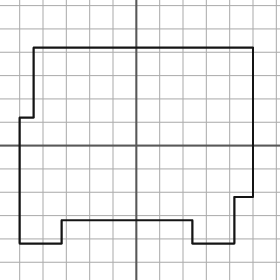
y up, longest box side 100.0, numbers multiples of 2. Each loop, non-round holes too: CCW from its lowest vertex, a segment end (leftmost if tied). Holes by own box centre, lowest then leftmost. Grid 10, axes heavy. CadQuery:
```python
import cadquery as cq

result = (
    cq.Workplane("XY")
    .moveTo(-50.0, -42.0)
    .lineTo(-32.0, -42.0)
    .lineTo(-32.0, -32.0)
    .lineTo(24.0, -32.0)
    .lineTo(24.0, -42.0)
    .lineTo(42.0, -42.0)
    .lineTo(42.0, -22.0)
    .lineTo(50.0, -22.0)
    .lineTo(50.0, 42.0)
    .lineTo(-44.0, 42.0)
    .lineTo(-44.0, 12.0)
    .lineTo(-50.0, 12.0)
    .close()
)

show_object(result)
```